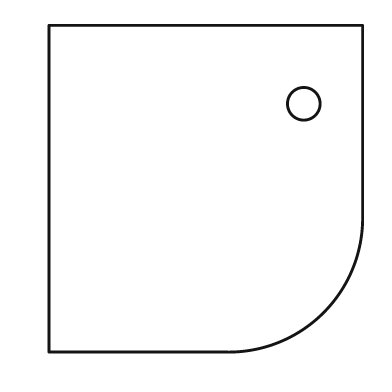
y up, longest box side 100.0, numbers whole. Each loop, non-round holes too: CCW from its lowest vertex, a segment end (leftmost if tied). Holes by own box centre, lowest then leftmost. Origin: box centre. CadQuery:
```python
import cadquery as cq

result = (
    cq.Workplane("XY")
    .moveTo(-48.0, -50.0)
    .lineTo(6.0, -50.0)
    .threePointArc((36.0, -38.0), (48.0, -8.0))
    .lineTo(48.0, 50.0)
    .lineTo(-48.0, 50.0)
    .close()
    .moveTo(30.0, 26.0)
    .circle(5.0)
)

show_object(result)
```